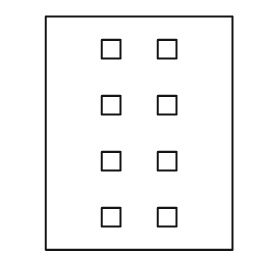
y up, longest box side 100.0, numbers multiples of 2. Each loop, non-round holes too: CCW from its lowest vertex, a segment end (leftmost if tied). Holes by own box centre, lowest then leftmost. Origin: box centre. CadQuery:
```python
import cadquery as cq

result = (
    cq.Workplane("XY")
    .moveTo(-40.0, -50.0)
    .lineTo(40.0, -50.0)
    .lineTo(40.0, 50.0)
    .lineTo(-40.0, 50.0)
    .close()
    .moveTo(-16.0, -40.0)
    .lineTo(-8.0, -40.0)
    .lineTo(-8.0, -32.0)
    .lineTo(-16.0, -32.0)
    .close()
    .moveTo(8.0, -40.0)
    .lineTo(16.0, -40.0)
    .lineTo(16.0, -32.0)
    .lineTo(8.0, -32.0)
    .close()
    .moveTo(-16.0, -16.0)
    .lineTo(-8.0, -16.0)
    .lineTo(-8.0, -8.0)
    .lineTo(-16.0, -8.0)
    .close()
    .moveTo(8.0, -16.0)
    .lineTo(16.0, -16.0)
    .lineTo(16.0, -8.0)
    .lineTo(8.0, -8.0)
    .close()
    .moveTo(-16.0, 8.0)
    .lineTo(-8.0, 8.0)
    .lineTo(-8.0, 16.0)
    .lineTo(-16.0, 16.0)
    .close()
    .moveTo(8.0, 8.0)
    .lineTo(16.0, 8.0)
    .lineTo(16.0, 16.0)
    .lineTo(8.0, 16.0)
    .close()
    .moveTo(-16.0, 32.0)
    .lineTo(-8.0, 32.0)
    .lineTo(-8.0, 40.0)
    .lineTo(-16.0, 40.0)
    .close()
    .moveTo(8.0, 32.0)
    .lineTo(16.0, 32.0)
    .lineTo(16.0, 40.0)
    .lineTo(8.0, 40.0)
    .close()
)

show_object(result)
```